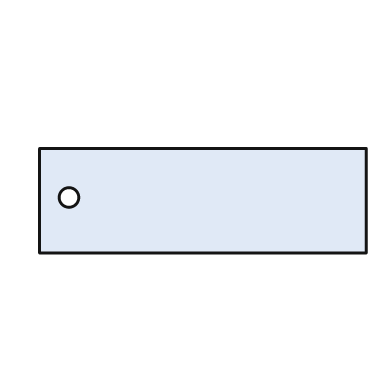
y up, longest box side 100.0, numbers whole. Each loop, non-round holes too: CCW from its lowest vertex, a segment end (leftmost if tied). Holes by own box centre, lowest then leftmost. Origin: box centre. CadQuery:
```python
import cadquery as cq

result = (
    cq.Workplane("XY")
    .moveTo(-50.0, -16.0)
    .lineTo(50.0, -16.0)
    .lineTo(50.0, 16.0)
    .lineTo(-50.0, 16.0)
    .close()
    .moveTo(-41.0, 1.0)
    .circle(3.0)
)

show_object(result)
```